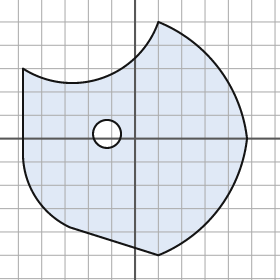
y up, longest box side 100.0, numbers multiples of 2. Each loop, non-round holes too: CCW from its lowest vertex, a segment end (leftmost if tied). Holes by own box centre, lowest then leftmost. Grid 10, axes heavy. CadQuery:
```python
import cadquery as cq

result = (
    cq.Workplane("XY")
    .moveTo(10.0, -50.0)
    .threePointArc((36.0, -30.0), (48.0, 0.0))
    .threePointArc((36.0, 30.0), (10.0, 50.0))
    .threePointArc((-14.0, 26.0), (-48.0, 30.0))
    .lineTo(-48.0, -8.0)
    .threePointArc((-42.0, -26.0), (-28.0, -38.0))
    .close()
    .moveTo(-12.0, 2.0)
    .circle(6.0)
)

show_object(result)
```